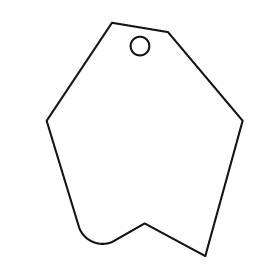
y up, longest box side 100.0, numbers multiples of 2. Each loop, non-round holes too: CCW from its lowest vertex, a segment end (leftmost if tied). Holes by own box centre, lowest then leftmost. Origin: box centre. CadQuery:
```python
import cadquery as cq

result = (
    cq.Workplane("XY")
    .moveTo(26.0, -50.0)
    .lineTo(42.0, 8.0)
    .lineTo(10.0, 46.0)
    .lineTo(-14.0, 50.0)
    .lineTo(-42.0, 8.0)
    .lineTo(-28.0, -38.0)
    .threePointArc((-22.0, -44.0), (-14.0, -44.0))
    .lineTo(0.0, -36.0)
    .close()
    .moveTo(-2.0, 40.0)
    .circle(4.0)
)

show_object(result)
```